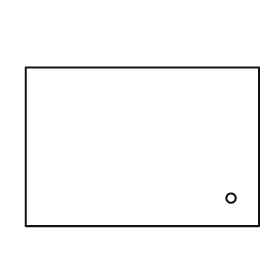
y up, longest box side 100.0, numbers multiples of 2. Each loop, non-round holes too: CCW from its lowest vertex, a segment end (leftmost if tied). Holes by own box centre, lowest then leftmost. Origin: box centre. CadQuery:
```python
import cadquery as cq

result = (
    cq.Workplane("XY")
    .moveTo(-50.0, -34.0)
    .lineTo(50.0, -34.0)
    .lineTo(50.0, 34.0)
    .lineTo(-50.0, 34.0)
    .close()
    .moveTo(38.0, -22.0)
    .circle(2.0)
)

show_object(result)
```